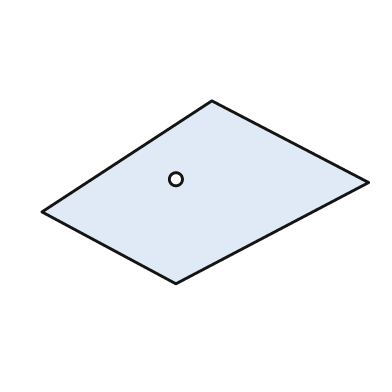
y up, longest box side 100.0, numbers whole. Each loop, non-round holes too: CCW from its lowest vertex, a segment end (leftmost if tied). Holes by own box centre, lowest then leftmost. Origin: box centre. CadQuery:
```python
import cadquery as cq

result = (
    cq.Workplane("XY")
    .moveTo(-9.0, -28.0)
    .lineTo(50.0, 3.0)
    .lineTo(2.0, 28.0)
    .lineTo(-50.0, -6.0)
    .close()
    .moveTo(-9.0, 4.0)
    .circle(2.0)
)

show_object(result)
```